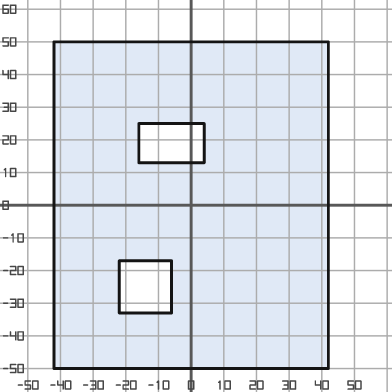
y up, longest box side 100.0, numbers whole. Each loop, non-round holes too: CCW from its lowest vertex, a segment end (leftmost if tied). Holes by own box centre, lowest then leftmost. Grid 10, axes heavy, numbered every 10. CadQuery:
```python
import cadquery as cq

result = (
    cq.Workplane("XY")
    .moveTo(-42.0, -50.0)
    .lineTo(42.0, -50.0)
    .lineTo(42.0, 50.0)
    .lineTo(-42.0, 50.0)
    .close()
    .moveTo(-22.0, -33.0)
    .lineTo(-6.0, -33.0)
    .lineTo(-6.0, -17.0)
    .lineTo(-22.0, -17.0)
    .close()
    .moveTo(-16.0, 13.0)
    .lineTo(4.0, 13.0)
    .lineTo(4.0, 25.0)
    .lineTo(-16.0, 25.0)
    .close()
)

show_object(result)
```